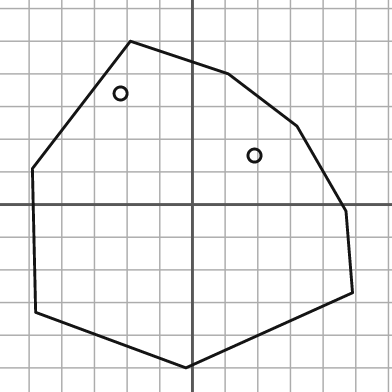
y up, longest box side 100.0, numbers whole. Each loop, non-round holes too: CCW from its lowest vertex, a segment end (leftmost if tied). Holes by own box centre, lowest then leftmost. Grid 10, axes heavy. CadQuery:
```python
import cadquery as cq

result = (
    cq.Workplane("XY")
    .moveTo(-2.0, -50.0)
    .lineTo(49.0, -27.0)
    .lineTo(47.0, -2.0)
    .lineTo(32.0, 24.0)
    .lineTo(11.0, 40.0)
    .lineTo(-19.0, 50.0)
    .lineTo(-49.0, 11.0)
    .lineTo(-48.0, -33.0)
    .close()
    .moveTo(19.0, 15.0)
    .circle(2.0)
    .moveTo(-22.0, 34.0)
    .circle(2.0)
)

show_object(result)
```